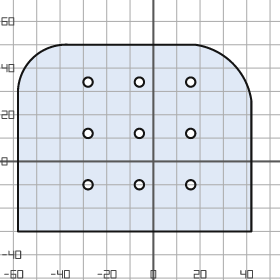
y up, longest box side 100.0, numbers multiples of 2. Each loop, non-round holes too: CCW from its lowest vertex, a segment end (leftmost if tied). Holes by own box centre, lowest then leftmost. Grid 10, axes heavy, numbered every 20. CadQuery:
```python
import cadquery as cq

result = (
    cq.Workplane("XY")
    .moveTo(-58.0, -30.0)
    .lineTo(42.0, -30.0)
    .lineTo(42.0, 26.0)
    .threePointArc((34.0, 42.0), (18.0, 50.0))
    .lineTo(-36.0, 50.0)
    .threePointArc((-52.0, 44.0), (-58.0, 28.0))
    .close()
    .moveTo(-28.0, -10.0)
    .circle(2.0)
    .moveTo(-6.0, -10.0)
    .circle(2.0)
    .moveTo(16.0, -10.0)
    .circle(2.0)
    .moveTo(-28.0, 12.0)
    .circle(2.0)
    .moveTo(-6.0, 12.0)
    .circle(2.0)
    .moveTo(16.0, 12.0)
    .circle(2.0)
    .moveTo(-28.0, 34.0)
    .circle(2.0)
    .moveTo(-6.0, 34.0)
    .circle(2.0)
    .moveTo(16.0, 34.0)
    .circle(2.0)
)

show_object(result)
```